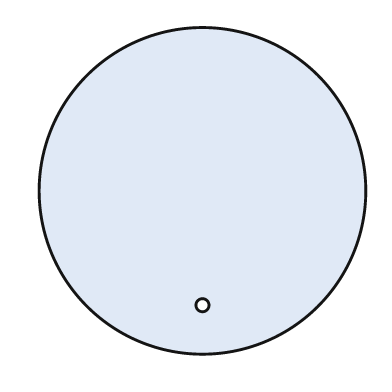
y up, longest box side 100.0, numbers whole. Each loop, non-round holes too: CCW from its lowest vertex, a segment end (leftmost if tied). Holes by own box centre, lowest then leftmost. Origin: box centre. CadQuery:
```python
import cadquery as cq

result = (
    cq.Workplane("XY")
    .moveTo(0.0, 0.0)
    .circle(50.0)
    .moveTo(0.0, -35.0)
    .circle(2.0)
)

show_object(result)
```